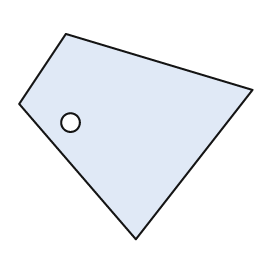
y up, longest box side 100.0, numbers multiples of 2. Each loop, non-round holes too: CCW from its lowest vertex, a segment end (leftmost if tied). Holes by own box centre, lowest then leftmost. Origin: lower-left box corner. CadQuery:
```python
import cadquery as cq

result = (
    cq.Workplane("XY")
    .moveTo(50.0, 0.0)
    .lineTo(100.0, 64.0)
    .lineTo(20.0, 88.0)
    .lineTo(0.0, 58.0)
    .close()
    .moveTo(22.0, 50.0)
    .circle(4.0)
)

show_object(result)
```